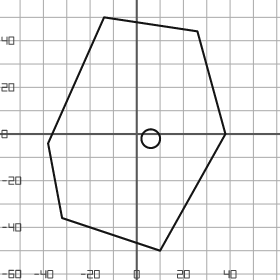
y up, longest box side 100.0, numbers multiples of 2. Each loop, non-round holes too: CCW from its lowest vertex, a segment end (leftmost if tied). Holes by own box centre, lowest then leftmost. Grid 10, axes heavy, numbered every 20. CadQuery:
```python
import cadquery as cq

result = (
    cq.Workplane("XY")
    .moveTo(10.0, -50.0)
    .lineTo(38.0, 0.0)
    .lineTo(26.0, 44.0)
    .lineTo(-14.0, 50.0)
    .lineTo(-38.0, -4.0)
    .lineTo(-32.0, -36.0)
    .close()
    .moveTo(6.0, -2.0)
    .circle(4.0)
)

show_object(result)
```